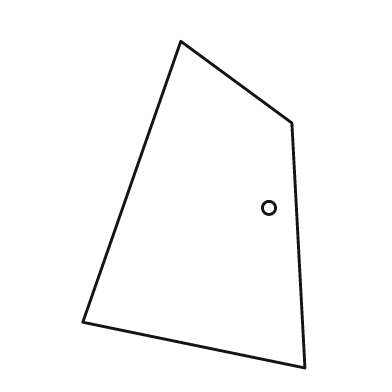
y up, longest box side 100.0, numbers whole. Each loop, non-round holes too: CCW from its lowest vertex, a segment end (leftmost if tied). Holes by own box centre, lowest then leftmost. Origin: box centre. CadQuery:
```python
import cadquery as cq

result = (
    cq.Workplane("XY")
    .moveTo(34.0, -50.0)
    .lineTo(30.0, 25.0)
    .lineTo(-4.0, 50.0)
    .lineTo(-34.0, -36.0)
    .close()
    .moveTo(23.0, -1.0)
    .circle(2.0)
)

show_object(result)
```